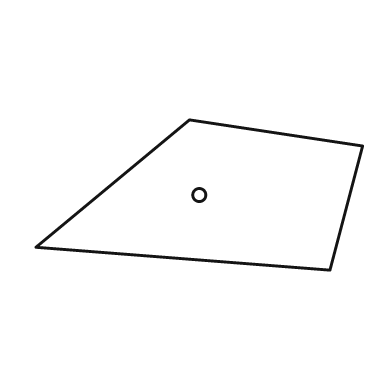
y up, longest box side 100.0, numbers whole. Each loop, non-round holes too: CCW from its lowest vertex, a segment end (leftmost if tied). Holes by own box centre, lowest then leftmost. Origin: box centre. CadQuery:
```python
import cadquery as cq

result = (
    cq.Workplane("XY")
    .moveTo(40.0, -23.0)
    .lineTo(50.0, 15.0)
    .lineTo(-3.0, 23.0)
    .lineTo(-50.0, -16.0)
    .close()
    .moveTo(0.0, 0.0)
    .circle(2.0)
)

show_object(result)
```